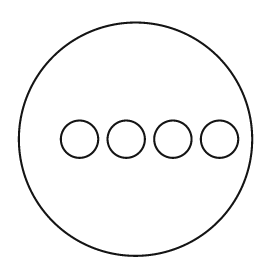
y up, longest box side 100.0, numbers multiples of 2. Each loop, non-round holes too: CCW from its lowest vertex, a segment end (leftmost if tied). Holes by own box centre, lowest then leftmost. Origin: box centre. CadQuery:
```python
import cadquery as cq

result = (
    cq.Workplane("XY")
    .moveTo(0.0, 0.0)
    .circle(50.0)
    .moveTo(-24.0, 0.0)
    .circle(8.0)
    .moveTo(-4.0, 0.0)
    .circle(8.0)
    .moveTo(16.0, 0.0)
    .circle(8.0)
    .moveTo(36.0, 0.0)
    .circle(8.0)
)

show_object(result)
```